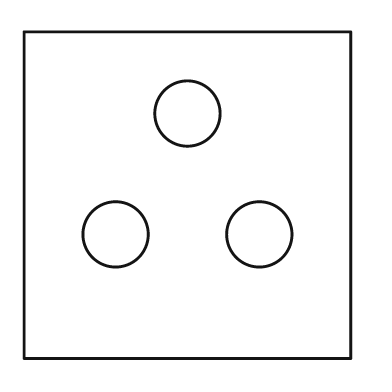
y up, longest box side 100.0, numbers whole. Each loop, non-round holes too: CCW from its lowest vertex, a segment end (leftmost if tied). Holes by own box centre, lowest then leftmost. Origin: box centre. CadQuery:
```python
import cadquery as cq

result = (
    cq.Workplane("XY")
    .moveTo(-50.0, -50.0)
    .lineTo(50.0, -50.0)
    .lineTo(50.0, 50.0)
    .lineTo(-50.0, 50.0)
    .close()
    .moveTo(-22.0, -12.0)
    .circle(10.0)
    .moveTo(22.0, -12.0)
    .circle(10.0)
    .moveTo(0.0, 25.0)
    .circle(10.0)
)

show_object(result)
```